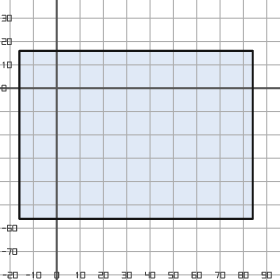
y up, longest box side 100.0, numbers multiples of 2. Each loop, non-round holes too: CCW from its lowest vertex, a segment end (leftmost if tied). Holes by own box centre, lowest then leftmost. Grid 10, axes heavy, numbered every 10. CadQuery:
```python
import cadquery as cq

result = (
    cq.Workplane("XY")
    .moveTo(-16.0, -56.0)
    .lineTo(84.0, -56.0)
    .lineTo(84.0, 16.0)
    .lineTo(-16.0, 16.0)
    .close()
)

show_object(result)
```